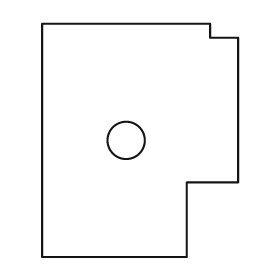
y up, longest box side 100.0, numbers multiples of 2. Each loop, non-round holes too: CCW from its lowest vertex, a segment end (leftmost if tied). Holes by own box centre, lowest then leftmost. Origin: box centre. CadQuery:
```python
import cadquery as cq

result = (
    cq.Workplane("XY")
    .moveTo(-42.0, -50.0)
    .lineTo(20.0, -50.0)
    .lineTo(20.0, -18.0)
    .lineTo(42.0, -18.0)
    .lineTo(42.0, 44.0)
    .lineTo(30.0, 44.0)
    .lineTo(30.0, 50.0)
    .lineTo(-42.0, 50.0)
    .close()
    .moveTo(-6.0, 0.0)
    .circle(8.0)
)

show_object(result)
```